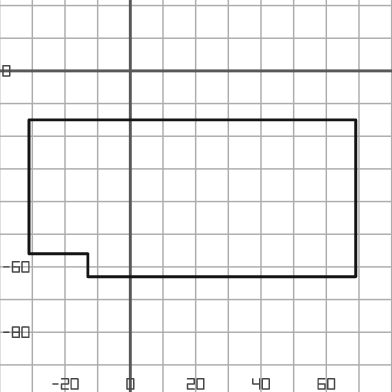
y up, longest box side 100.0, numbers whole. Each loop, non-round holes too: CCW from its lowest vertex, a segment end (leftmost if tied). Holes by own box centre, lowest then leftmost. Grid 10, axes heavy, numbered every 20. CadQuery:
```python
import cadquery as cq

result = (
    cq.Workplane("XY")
    .moveTo(-13.0, -63.0)
    .lineTo(69.0, -63.0)
    .lineTo(69.0, -15.0)
    .lineTo(-31.0, -15.0)
    .lineTo(-31.0, -56.0)
    .lineTo(-13.0, -56.0)
    .close()
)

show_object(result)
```